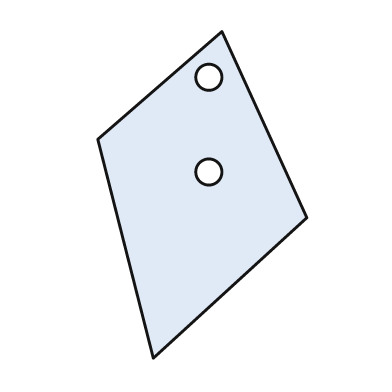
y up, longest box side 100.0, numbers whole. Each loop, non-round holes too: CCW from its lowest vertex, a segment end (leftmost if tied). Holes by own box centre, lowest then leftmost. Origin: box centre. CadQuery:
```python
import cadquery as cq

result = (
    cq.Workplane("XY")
    .moveTo(-15.0, -50.0)
    .lineTo(32.0, -7.0)
    .lineTo(6.0, 50.0)
    .lineTo(-32.0, 17.0)
    .close()
    .moveTo(2.0, 7.0)
    .circle(4.0)
    .moveTo(2.0, 36.0)
    .circle(4.0)
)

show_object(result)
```